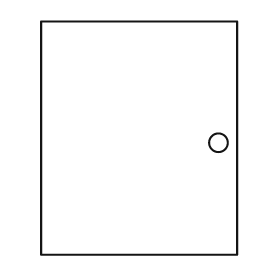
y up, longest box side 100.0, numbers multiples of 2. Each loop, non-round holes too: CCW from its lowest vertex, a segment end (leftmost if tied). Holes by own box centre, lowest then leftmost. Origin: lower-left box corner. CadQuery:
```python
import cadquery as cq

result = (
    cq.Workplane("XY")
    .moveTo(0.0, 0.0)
    .lineTo(84.0, 0.0)
    .lineTo(84.0, 100.0)
    .lineTo(0.0, 100.0)
    .close()
    .moveTo(76.0, 48.0)
    .circle(4.0)
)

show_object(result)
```